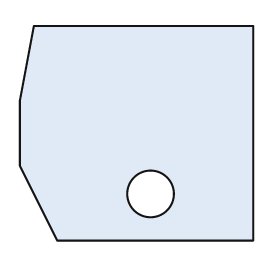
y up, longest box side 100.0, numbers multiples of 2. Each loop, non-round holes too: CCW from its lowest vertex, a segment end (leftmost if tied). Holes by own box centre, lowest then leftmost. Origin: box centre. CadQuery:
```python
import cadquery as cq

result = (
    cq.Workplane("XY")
    .moveTo(-34.0, -46.0)
    .lineTo(50.0, -46.0)
    .lineTo(50.0, 46.0)
    .lineTo(-44.0, 46.0)
    .lineTo(-50.0, 14.0)
    .lineTo(-50.0, -14.0)
    .close()
    .moveTo(6.0, -26.0)
    .circle(10.0)
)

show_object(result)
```